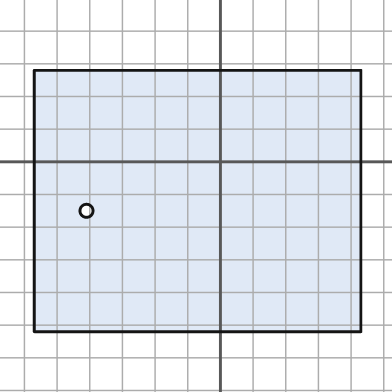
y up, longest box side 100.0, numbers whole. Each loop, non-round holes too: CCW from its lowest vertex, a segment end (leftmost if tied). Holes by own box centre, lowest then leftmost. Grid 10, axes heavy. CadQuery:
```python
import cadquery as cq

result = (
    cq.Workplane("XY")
    .moveTo(-57.0, -52.0)
    .lineTo(43.0, -52.0)
    .lineTo(43.0, 28.0)
    .lineTo(-57.0, 28.0)
    .close()
    .moveTo(-41.0, -15.0)
    .circle(2.0)
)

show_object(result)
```